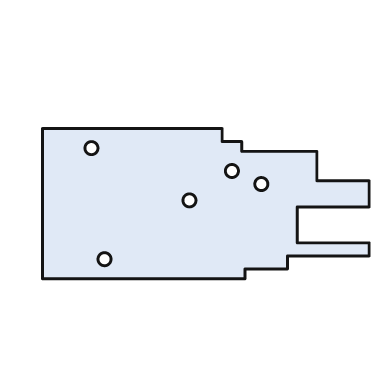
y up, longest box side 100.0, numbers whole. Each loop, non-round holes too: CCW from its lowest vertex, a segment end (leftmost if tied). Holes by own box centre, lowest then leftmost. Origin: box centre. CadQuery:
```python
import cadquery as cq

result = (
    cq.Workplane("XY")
    .moveTo(-50.0, -23.0)
    .lineTo(12.0, -23.0)
    .lineTo(12.0, -20.0)
    .lineTo(25.0, -20.0)
    .lineTo(25.0, -16.0)
    .lineTo(50.0, -16.0)
    .lineTo(50.0, -12.0)
    .lineTo(28.0, -12.0)
    .lineTo(28.0, -1.0)
    .lineTo(50.0, -1.0)
    .lineTo(50.0, 7.0)
    .lineTo(34.0, 7.0)
    .lineTo(34.0, 16.0)
    .lineTo(11.0, 16.0)
    .lineTo(11.0, 19.0)
    .lineTo(5.0, 19.0)
    .lineTo(5.0, 23.0)
    .lineTo(-50.0, 23.0)
    .close()
    .moveTo(-31.0, -17.0)
    .circle(2.0)
    .moveTo(-5.0, 1.0)
    .circle(2.0)
    .moveTo(17.0, 6.0)
    .circle(2.0)
    .moveTo(8.0, 10.0)
    .circle(2.0)
    .moveTo(-35.0, 17.0)
    .circle(2.0)
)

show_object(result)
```